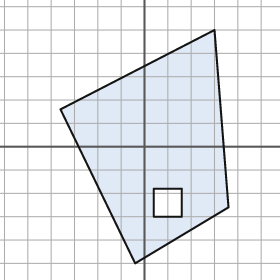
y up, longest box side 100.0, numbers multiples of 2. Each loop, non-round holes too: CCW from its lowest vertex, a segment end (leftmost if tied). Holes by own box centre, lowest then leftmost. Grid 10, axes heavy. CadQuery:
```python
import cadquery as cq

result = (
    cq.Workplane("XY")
    .moveTo(-4.0, -50.0)
    .lineTo(36.0, -26.0)
    .lineTo(30.0, 50.0)
    .lineTo(-36.0, 16.0)
    .close()
    .moveTo(4.0, -30.0)
    .lineTo(16.0, -30.0)
    .lineTo(16.0, -18.0)
    .lineTo(4.0, -18.0)
    .close()
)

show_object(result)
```